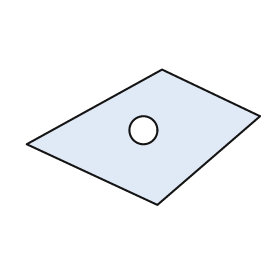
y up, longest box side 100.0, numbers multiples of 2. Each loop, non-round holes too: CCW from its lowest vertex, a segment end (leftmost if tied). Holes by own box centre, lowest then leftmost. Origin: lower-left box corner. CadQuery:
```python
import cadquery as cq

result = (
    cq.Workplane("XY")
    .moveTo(56.0, 0.0)
    .lineTo(100.0, 38.0)
    .lineTo(58.0, 58.0)
    .lineTo(0.0, 26.0)
    .close()
    .moveTo(50.0, 32.0)
    .circle(6.0)
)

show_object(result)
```